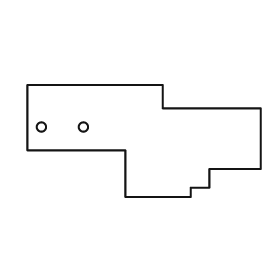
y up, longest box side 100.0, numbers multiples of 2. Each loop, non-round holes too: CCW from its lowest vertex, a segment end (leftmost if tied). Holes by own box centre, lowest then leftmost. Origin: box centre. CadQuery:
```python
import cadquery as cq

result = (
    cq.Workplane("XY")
    .moveTo(-8.0, -24.0)
    .lineTo(20.0, -24.0)
    .lineTo(20.0, -20.0)
    .lineTo(28.0, -20.0)
    .lineTo(28.0, -12.0)
    .lineTo(50.0, -12.0)
    .lineTo(50.0, 14.0)
    .lineTo(8.0, 14.0)
    .lineTo(8.0, 24.0)
    .lineTo(-50.0, 24.0)
    .lineTo(-50.0, -4.0)
    .lineTo(-8.0, -4.0)
    .close()
    .moveTo(-44.0, 6.0)
    .circle(2.0)
    .moveTo(-26.0, 6.0)
    .circle(2.0)
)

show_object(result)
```